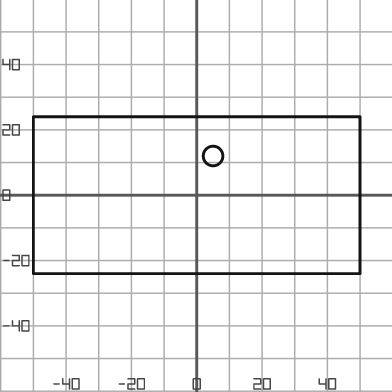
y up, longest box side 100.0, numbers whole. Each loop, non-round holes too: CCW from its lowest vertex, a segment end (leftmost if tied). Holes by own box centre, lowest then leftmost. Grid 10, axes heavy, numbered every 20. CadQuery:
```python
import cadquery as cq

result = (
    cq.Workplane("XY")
    .moveTo(-50.0, -24.0)
    .lineTo(50.0, -24.0)
    .lineTo(50.0, 24.0)
    .lineTo(-50.0, 24.0)
    .close()
    .moveTo(5.0, 12.0)
    .circle(3.0)
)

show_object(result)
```